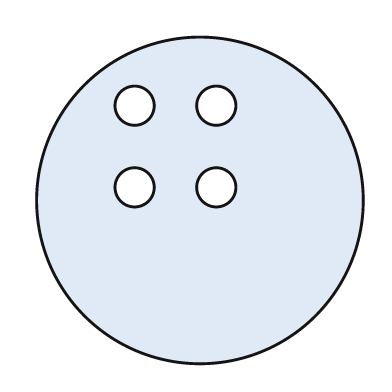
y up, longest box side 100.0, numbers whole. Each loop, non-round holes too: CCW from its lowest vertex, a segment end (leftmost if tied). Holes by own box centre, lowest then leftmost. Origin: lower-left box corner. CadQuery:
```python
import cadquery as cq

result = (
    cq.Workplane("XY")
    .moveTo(50.0, 50.0)
    .circle(50.0)
    .moveTo(30.0, 54.0)
    .circle(6.0)
    .moveTo(55.0, 54.0)
    .circle(6.0)
    .moveTo(30.0, 79.0)
    .circle(6.0)
    .moveTo(55.0, 79.0)
    .circle(6.0)
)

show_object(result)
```